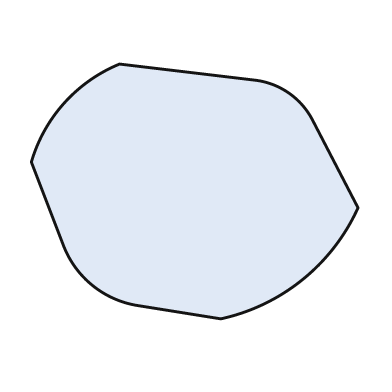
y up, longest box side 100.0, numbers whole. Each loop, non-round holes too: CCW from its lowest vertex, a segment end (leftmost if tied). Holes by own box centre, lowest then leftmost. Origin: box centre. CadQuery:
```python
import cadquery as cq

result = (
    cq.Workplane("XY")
    .moveTo(8.0, -39.0)
    .threePointArc((33.0, -27.0), (50.0, -5.0))
    .lineTo(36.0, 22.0)
    .threePointArc((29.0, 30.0), (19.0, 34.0))
    .lineTo(-23.0, 39.0)
    .threePointArc((-40.0, 27.0), (-50.0, 9.0))
    .lineTo(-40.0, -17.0)
    .threePointArc((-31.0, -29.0), (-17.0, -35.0))
    .close()
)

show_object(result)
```